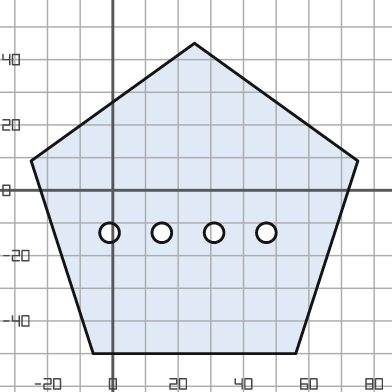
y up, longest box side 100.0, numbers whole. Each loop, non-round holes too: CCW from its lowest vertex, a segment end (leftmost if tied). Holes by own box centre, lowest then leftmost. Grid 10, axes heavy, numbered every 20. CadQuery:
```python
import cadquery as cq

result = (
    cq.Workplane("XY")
    .moveTo(-6.0, -50.0)
    .lineTo(56.0, -50.0)
    .lineTo(75.0, 9.0)
    .lineTo(25.0, 45.0)
    .lineTo(-25.0, 9.0)
    .close()
    .moveTo(-1.0, -13.0)
    .circle(3.0)
    .moveTo(15.0, -13.0)
    .circle(3.0)
    .moveTo(31.0, -13.0)
    .circle(3.0)
    .moveTo(47.0, -13.0)
    .circle(3.0)
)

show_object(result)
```